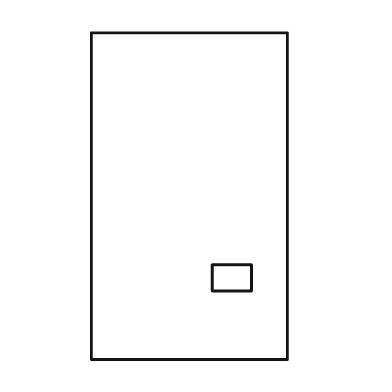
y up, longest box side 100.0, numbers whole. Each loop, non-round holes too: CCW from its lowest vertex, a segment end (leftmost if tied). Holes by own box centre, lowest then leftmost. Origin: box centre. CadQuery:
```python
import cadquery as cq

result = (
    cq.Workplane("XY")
    .moveTo(-30.0, -50.0)
    .lineTo(30.0, -50.0)
    .lineTo(30.0, 50.0)
    .lineTo(-30.0, 50.0)
    .close()
    .moveTo(7.0, -29.0)
    .lineTo(19.0, -29.0)
    .lineTo(19.0, -21.0)
    .lineTo(7.0, -21.0)
    .close()
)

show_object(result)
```